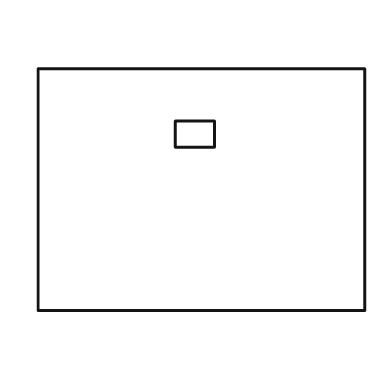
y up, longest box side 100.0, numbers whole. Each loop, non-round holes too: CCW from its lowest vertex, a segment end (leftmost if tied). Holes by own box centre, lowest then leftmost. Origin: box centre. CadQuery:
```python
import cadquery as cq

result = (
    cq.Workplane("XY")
    .moveTo(-50.0, -37.0)
    .lineTo(50.0, -37.0)
    .lineTo(50.0, 37.0)
    .lineTo(-50.0, 37.0)
    .close()
    .moveTo(-8.0, 13.0)
    .lineTo(4.0, 13.0)
    .lineTo(4.0, 21.0)
    .lineTo(-8.0, 21.0)
    .close()
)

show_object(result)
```